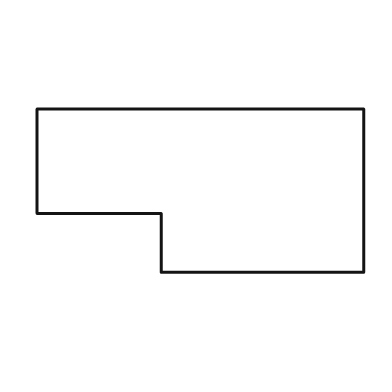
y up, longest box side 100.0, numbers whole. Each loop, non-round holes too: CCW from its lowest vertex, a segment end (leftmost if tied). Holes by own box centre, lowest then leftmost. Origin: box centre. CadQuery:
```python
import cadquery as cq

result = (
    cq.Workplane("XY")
    .moveTo(-12.0, -25.0)
    .lineTo(50.0, -25.0)
    .lineTo(50.0, 25.0)
    .lineTo(-50.0, 25.0)
    .lineTo(-50.0, -7.0)
    .lineTo(-12.0, -7.0)
    .close()
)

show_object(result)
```